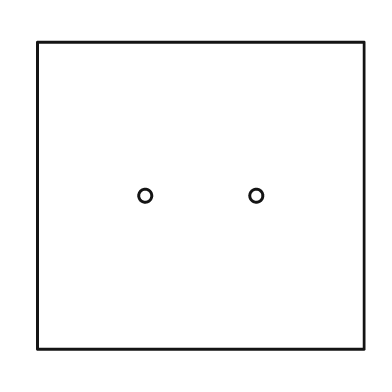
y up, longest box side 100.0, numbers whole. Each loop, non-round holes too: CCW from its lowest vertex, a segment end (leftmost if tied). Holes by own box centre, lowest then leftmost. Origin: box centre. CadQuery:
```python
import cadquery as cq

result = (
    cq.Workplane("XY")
    .moveTo(-50.0, -47.0)
    .lineTo(50.0, -47.0)
    .lineTo(50.0, 47.0)
    .lineTo(-50.0, 47.0)
    .close()
    .moveTo(-17.0, 0.0)
    .circle(2.0)
    .moveTo(17.0, 0.0)
    .circle(2.0)
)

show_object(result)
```